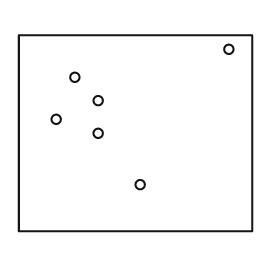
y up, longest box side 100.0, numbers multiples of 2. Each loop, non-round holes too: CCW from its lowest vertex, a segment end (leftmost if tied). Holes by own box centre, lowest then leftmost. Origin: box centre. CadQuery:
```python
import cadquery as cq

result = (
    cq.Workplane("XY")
    .moveTo(-50.0, -42.0)
    .lineTo(50.0, -42.0)
    .lineTo(50.0, 42.0)
    .lineTo(-50.0, 42.0)
    .close()
    .moveTo(2.0, -22.0)
    .circle(2.0)
    .moveTo(-16.0, 0.0)
    .circle(2.0)
    .moveTo(-34.0, 6.0)
    .circle(2.0)
    .moveTo(-16.0, 14.0)
    .circle(2.0)
    .moveTo(-26.0, 24.0)
    .circle(2.0)
    .moveTo(40.0, 36.0)
    .circle(2.0)
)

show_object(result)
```